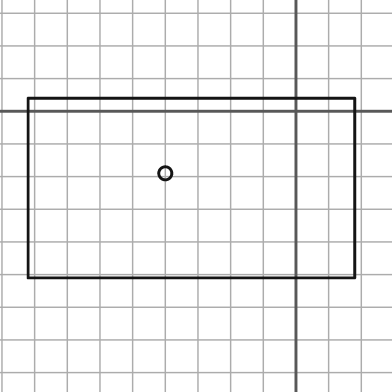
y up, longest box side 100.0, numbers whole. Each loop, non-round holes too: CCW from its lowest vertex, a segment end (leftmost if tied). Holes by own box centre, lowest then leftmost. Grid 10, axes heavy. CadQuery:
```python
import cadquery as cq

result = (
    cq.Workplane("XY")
    .moveTo(-82.0, -51.0)
    .lineTo(18.0, -51.0)
    .lineTo(18.0, 4.0)
    .lineTo(-82.0, 4.0)
    .close()
    .moveTo(-40.0, -19.0)
    .circle(2.0)
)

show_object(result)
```